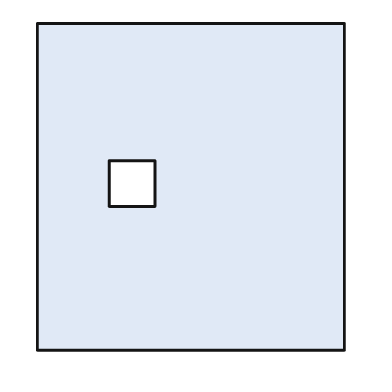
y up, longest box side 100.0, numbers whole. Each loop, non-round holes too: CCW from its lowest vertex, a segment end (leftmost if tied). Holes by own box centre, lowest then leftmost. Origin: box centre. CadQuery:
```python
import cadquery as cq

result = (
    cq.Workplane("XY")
    .moveTo(-47.0, -50.0)
    .lineTo(47.0, -50.0)
    .lineTo(47.0, 50.0)
    .lineTo(-47.0, 50.0)
    .close()
    .moveTo(-25.0, -6.0)
    .lineTo(-11.0, -6.0)
    .lineTo(-11.0, 8.0)
    .lineTo(-25.0, 8.0)
    .close()
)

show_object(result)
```